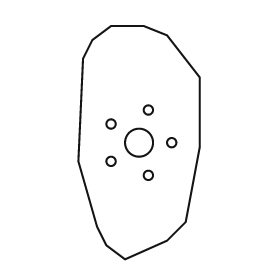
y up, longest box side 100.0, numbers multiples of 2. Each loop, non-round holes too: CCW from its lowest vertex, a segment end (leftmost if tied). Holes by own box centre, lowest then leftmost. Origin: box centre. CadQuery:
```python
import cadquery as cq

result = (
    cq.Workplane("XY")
    .moveTo(-6.0, -50.0)
    .lineTo(12.0, -42.0)
    .lineTo(20.0, -34.0)
    .lineTo(26.0, -2.0)
    .lineTo(26.0, 28.0)
    .lineTo(12.0, 46.0)
    .lineTo(2.0, 50.0)
    .lineTo(-12.0, 50.0)
    .lineTo(-20.0, 44.0)
    .lineTo(-24.0, 36.0)
    .lineTo(-26.0, -8.0)
    .lineTo(-18.0, -36.0)
    .lineTo(-14.0, -44.0)
    .close()
    .moveTo(4.0, -14.0)
    .circle(2.0)
    .moveTo(-12.0, -8.0)
    .circle(2.0)
    .moveTo(0.0, 0.0)
    .circle(6.0)
    .moveTo(14.0, 0.0)
    .circle(2.0)
    .moveTo(-12.0, 8.0)
    .circle(2.0)
    .moveTo(4.0, 14.0)
    .circle(2.0)
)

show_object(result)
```